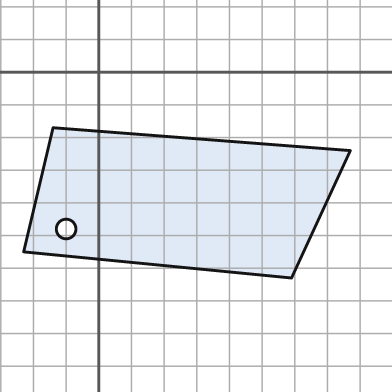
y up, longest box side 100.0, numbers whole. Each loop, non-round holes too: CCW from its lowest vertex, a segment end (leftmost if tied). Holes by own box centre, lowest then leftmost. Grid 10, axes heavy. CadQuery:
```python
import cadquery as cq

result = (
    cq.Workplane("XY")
    .moveTo(59.0, -63.0)
    .lineTo(77.0, -24.0)
    .lineTo(-14.0, -17.0)
    .lineTo(-23.0, -55.0)
    .close()
    .moveTo(-10.0, -48.0)
    .circle(3.0)
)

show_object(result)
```